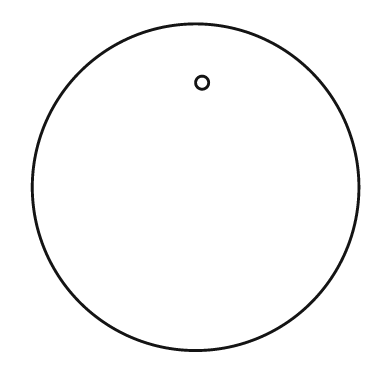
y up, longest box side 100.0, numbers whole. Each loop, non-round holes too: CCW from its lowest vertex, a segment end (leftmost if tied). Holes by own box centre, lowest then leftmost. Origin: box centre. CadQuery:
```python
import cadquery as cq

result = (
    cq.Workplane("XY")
    .moveTo(0.0, 0.0)
    .circle(50.0)
    .moveTo(2.0, 32.0)
    .circle(2.0)
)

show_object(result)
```